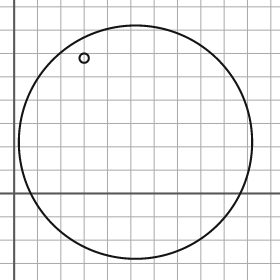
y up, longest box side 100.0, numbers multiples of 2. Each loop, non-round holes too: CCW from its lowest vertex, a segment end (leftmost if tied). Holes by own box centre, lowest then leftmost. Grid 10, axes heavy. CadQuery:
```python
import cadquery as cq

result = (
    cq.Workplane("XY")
    .moveTo(52.0, 22.0)
    .circle(50.0)
    .moveTo(30.0, 58.0)
    .circle(2.0)
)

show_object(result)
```